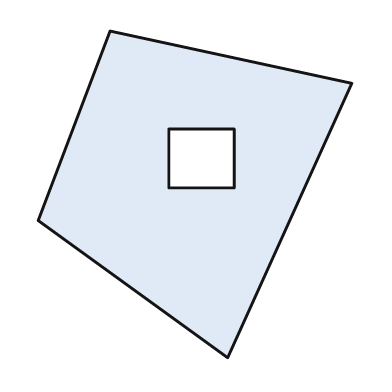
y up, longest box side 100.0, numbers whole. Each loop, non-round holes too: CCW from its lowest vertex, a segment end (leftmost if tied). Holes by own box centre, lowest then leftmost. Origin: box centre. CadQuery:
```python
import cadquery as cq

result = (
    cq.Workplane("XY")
    .moveTo(10.0, -50.0)
    .lineTo(48.0, 34.0)
    .lineTo(-26.0, 50.0)
    .lineTo(-48.0, -8.0)
    .close()
    .moveTo(-8.0, 2.0)
    .lineTo(12.0, 2.0)
    .lineTo(12.0, 20.0)
    .lineTo(-8.0, 20.0)
    .close()
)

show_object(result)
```